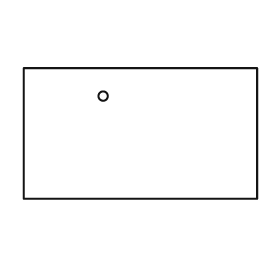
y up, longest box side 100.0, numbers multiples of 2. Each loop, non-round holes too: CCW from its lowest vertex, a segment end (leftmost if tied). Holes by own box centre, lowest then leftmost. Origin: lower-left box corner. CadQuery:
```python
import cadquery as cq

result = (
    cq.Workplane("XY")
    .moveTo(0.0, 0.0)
    .lineTo(100.0, 0.0)
    .lineTo(100.0, 56.0)
    .lineTo(0.0, 56.0)
    .close()
    .moveTo(34.0, 44.0)
    .circle(2.0)
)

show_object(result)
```